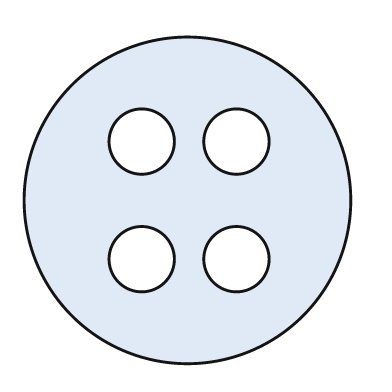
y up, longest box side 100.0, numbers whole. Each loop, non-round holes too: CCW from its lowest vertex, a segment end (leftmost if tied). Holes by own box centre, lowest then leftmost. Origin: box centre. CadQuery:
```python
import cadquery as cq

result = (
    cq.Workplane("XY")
    .moveTo(0.0, 0.0)
    .circle(50.0)
    .moveTo(-14.0, -18.0)
    .circle(10.0)
    .moveTo(15.0, -18.0)
    .circle(10.0)
    .moveTo(-14.0, 18.0)
    .circle(10.0)
    .moveTo(15.0, 18.0)
    .circle(10.0)
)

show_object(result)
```